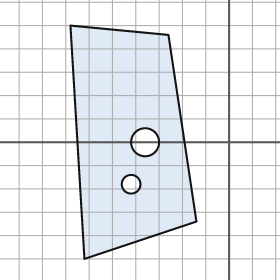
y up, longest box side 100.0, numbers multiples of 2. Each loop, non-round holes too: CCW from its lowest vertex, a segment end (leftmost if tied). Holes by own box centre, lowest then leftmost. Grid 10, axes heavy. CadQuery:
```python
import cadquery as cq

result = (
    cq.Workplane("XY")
    .moveTo(-62.0, -50.0)
    .lineTo(-14.0, -34.0)
    .lineTo(-26.0, 46.0)
    .lineTo(-68.0, 50.0)
    .close()
    .moveTo(-42.0, -18.0)
    .circle(4.0)
    .moveTo(-36.0, 0.0)
    .circle(6.0)
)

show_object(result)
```